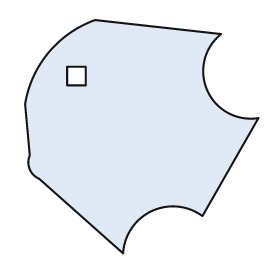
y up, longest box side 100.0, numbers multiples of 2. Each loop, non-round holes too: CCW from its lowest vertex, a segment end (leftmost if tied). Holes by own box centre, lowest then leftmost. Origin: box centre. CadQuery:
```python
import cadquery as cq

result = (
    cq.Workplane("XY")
    .moveTo(-8.0, -50.0)
    .threePointArc((4.0, -32.0), (26.0, -34.0))
    .lineTo(50.0, 8.0)
    .threePointArc((28.0, 20.0), (34.0, 44.0))
    .lineTo(-20.0, 50.0)
    .threePointArc((-40.0, 36.0), (-50.0, 14.0))
    .lineTo(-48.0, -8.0)
    .threePointArc((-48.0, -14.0), (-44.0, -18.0))
    .close()
    .moveTo(-32.0, 22.0)
    .lineTo(-24.0, 22.0)
    .lineTo(-24.0, 30.0)
    .lineTo(-32.0, 30.0)
    .close()
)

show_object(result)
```